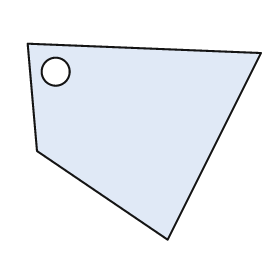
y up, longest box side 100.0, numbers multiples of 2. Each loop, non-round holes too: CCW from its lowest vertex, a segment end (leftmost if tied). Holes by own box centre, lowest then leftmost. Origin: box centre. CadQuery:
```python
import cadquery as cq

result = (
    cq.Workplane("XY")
    .moveTo(10.0, -42.0)
    .lineTo(50.0, 38.0)
    .lineTo(-50.0, 42.0)
    .lineTo(-46.0, -4.0)
    .close()
    .moveTo(-38.0, 30.0)
    .circle(6.0)
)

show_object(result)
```